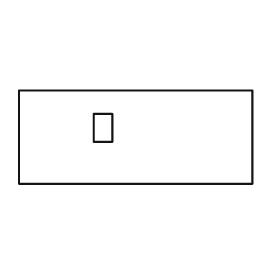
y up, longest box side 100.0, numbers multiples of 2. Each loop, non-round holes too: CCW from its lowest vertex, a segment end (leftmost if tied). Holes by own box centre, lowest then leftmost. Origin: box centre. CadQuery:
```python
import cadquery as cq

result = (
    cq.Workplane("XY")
    .moveTo(-50.0, -20.0)
    .lineTo(50.0, -20.0)
    .lineTo(50.0, 20.0)
    .lineTo(-50.0, 20.0)
    .close()
    .moveTo(-18.0, -2.0)
    .lineTo(-10.0, -2.0)
    .lineTo(-10.0, 10.0)
    .lineTo(-18.0, 10.0)
    .close()
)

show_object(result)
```